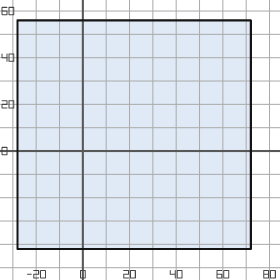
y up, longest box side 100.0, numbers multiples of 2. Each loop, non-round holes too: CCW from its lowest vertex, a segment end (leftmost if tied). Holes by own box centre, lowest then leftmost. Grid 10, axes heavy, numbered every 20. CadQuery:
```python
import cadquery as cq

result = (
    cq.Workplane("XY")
    .moveTo(-28.0, -42.0)
    .lineTo(72.0, -42.0)
    .lineTo(72.0, 56.0)
    .lineTo(-28.0, 56.0)
    .close()
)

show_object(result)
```